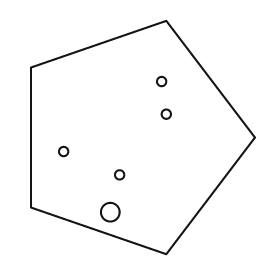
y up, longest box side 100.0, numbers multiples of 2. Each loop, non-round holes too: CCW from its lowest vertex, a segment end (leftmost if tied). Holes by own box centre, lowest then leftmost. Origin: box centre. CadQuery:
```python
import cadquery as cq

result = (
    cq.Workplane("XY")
    .moveTo(10.0, -50.0)
    .lineTo(48.0, 0.0)
    .lineTo(10.0, 50.0)
    .lineTo(-48.0, 30.0)
    .lineTo(-48.0, -30.0)
    .close()
    .moveTo(-14.0, -32.0)
    .circle(4.0)
    .moveTo(-10.0, -16.0)
    .circle(2.0)
    .moveTo(-34.0, -6.0)
    .circle(2.0)
    .moveTo(10.0, 10.0)
    .circle(2.0)
    .moveTo(8.0, 24.0)
    .circle(2.0)
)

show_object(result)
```